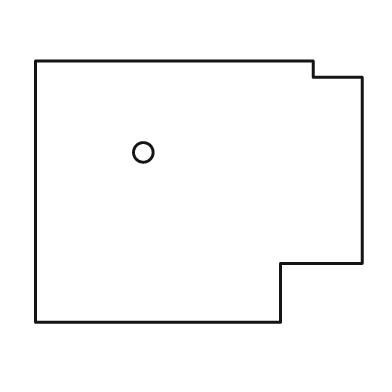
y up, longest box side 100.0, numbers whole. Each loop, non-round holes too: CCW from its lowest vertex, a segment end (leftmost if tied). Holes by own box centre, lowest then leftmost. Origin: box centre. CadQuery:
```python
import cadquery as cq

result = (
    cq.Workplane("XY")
    .moveTo(-50.0, -40.0)
    .lineTo(25.0, -40.0)
    .lineTo(25.0, -22.0)
    .lineTo(50.0, -22.0)
    .lineTo(50.0, 35.0)
    .lineTo(35.0, 35.0)
    .lineTo(35.0, 40.0)
    .lineTo(-50.0, 40.0)
    .close()
    .moveTo(-17.0, 12.0)
    .circle(3.0)
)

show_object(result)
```